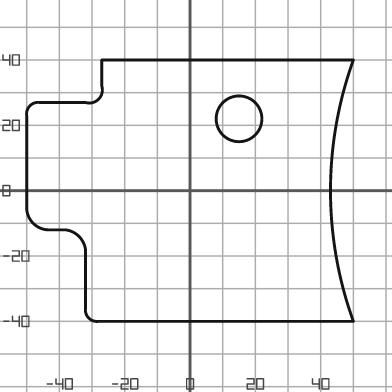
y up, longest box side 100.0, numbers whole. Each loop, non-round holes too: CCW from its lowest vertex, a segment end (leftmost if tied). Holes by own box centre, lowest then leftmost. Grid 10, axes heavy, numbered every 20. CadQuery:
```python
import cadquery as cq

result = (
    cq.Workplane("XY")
    .moveTo(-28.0, -40.0)
    .lineTo(50.0, -40.0)
    .threePointArc((43.0, 0.0), (50.0, 40.0))
    .lineTo(-27.0, 40.0)
    .lineTo(-27.0, 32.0)
    .threePointArc((-28.0, 28.0), (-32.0, 27.0))
    .lineTo(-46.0, 27.0)
    .threePointArc((-49.0, 26.0), (-50.0, 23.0))
    .lineTo(-50.0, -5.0)
    .threePointArc((-48.0, -10.0), (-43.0, -12.0))
    .lineTo(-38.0, -12.0)
    .threePointArc((-34.0, -14.0), (-32.0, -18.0))
    .lineTo(-32.0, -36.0)
    .threePointArc((-31.0, -39.0), (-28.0, -40.0))
    .close()
    .moveTo(15.0, 22.0)
    .circle(7.0)
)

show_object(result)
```